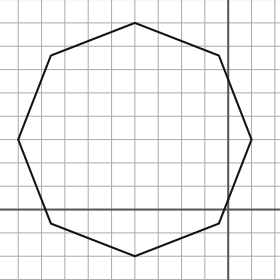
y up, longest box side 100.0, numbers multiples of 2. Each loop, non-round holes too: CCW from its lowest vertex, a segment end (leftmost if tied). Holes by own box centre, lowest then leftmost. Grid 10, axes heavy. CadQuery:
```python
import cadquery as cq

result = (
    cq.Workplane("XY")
    .moveTo(-40.0, -20.0)
    .lineTo(-4.0, -6.0)
    .lineTo(10.0, 30.0)
    .lineTo(-4.0, 66.0)
    .lineTo(-40.0, 80.0)
    .lineTo(-76.0, 66.0)
    .lineTo(-90.0, 30.0)
    .lineTo(-76.0, -6.0)
    .close()
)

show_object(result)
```